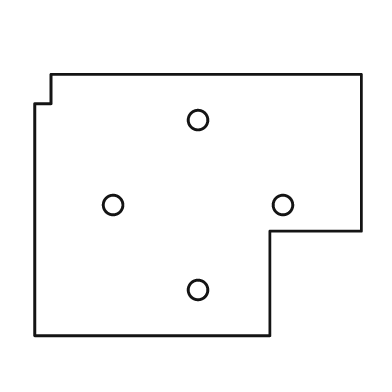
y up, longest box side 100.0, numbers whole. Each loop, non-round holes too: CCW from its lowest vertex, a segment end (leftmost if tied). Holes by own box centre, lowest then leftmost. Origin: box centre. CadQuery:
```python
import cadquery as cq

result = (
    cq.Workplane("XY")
    .moveTo(-50.0, -40.0)
    .lineTo(22.0, -40.0)
    .lineTo(22.0, -8.0)
    .lineTo(50.0, -8.0)
    .lineTo(50.0, 40.0)
    .lineTo(-45.0, 40.0)
    .lineTo(-45.0, 31.0)
    .lineTo(-50.0, 31.0)
    .close()
    .moveTo(0.0, -26.0)
    .circle(3.0)
    .moveTo(-26.0, 0.0)
    .circle(3.0)
    .moveTo(26.0, 0.0)
    .circle(3.0)
    .moveTo(0.0, 26.0)
    .circle(3.0)
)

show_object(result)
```